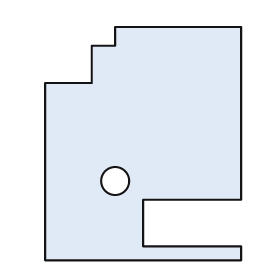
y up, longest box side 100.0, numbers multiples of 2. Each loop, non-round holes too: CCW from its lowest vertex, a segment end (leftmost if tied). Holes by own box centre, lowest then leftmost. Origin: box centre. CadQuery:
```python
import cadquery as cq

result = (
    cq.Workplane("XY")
    .moveTo(-42.0, -50.0)
    .lineTo(42.0, -50.0)
    .lineTo(42.0, -44.0)
    .lineTo(0.0, -44.0)
    .lineTo(0.0, -24.0)
    .lineTo(42.0, -24.0)
    .lineTo(42.0, 50.0)
    .lineTo(-12.0, 50.0)
    .lineTo(-12.0, 42.0)
    .lineTo(-22.0, 42.0)
    .lineTo(-22.0, 26.0)
    .lineTo(-42.0, 26.0)
    .close()
    .moveTo(-12.0, -16.0)
    .circle(6.0)
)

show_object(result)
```